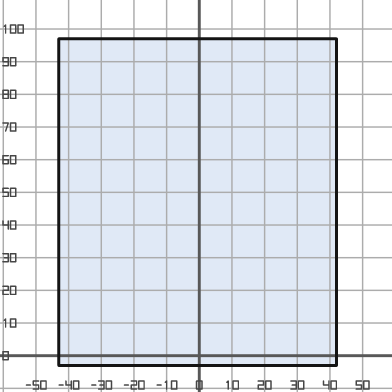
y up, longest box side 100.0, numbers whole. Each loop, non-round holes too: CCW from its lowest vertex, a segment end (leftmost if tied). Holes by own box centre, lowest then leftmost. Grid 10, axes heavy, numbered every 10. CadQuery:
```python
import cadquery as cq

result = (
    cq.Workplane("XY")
    .moveTo(-43.0, -3.0)
    .lineTo(42.0, -3.0)
    .lineTo(42.0, 97.0)
    .lineTo(-43.0, 97.0)
    .close()
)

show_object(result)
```